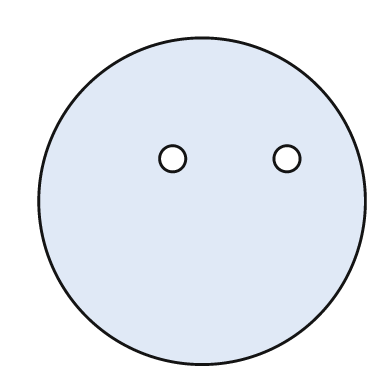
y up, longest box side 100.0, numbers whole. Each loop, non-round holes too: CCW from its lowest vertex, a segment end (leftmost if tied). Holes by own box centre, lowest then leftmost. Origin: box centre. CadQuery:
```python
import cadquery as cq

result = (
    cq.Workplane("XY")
    .moveTo(0.0, 0.0)
    .circle(50.0)
    .moveTo(-9.0, 13.0)
    .circle(4.0)
    .moveTo(26.0, 13.0)
    .circle(4.0)
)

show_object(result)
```